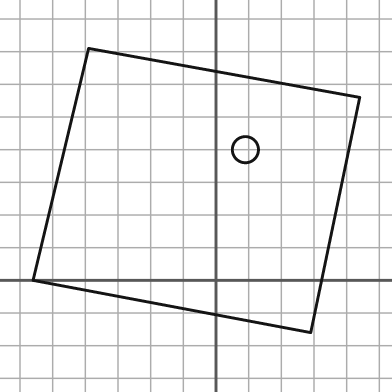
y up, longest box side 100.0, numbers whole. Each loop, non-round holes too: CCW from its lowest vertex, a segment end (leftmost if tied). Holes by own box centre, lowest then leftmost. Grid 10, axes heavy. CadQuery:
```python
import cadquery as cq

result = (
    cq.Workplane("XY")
    .moveTo(29.0, -16.0)
    .lineTo(44.0, 56.0)
    .lineTo(-39.0, 71.0)
    .lineTo(-56.0, 0.0)
    .close()
    .moveTo(9.0, 40.0)
    .circle(4.0)
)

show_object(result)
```